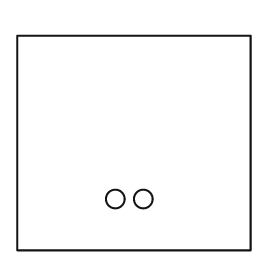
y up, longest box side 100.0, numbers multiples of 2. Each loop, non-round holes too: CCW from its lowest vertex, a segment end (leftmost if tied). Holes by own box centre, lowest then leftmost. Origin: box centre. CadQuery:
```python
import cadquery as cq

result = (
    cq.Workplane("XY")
    .moveTo(-50.0, -46.0)
    .lineTo(50.0, -46.0)
    .lineTo(50.0, 46.0)
    .lineTo(-50.0, 46.0)
    .close()
    .moveTo(-8.0, -24.0)
    .circle(4.0)
    .moveTo(4.0, -24.0)
    .circle(4.0)
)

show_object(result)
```